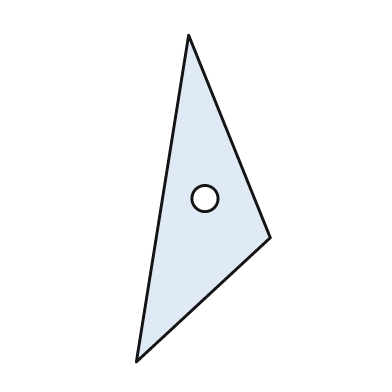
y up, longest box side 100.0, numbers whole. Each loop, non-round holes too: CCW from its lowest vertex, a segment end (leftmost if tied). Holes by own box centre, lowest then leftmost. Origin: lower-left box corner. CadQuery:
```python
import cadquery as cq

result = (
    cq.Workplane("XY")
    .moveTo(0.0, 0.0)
    .lineTo(41.0, 38.0)
    .lineTo(16.0, 100.0)
    .close()
    .moveTo(21.0, 50.0)
    .circle(4.0)
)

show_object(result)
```